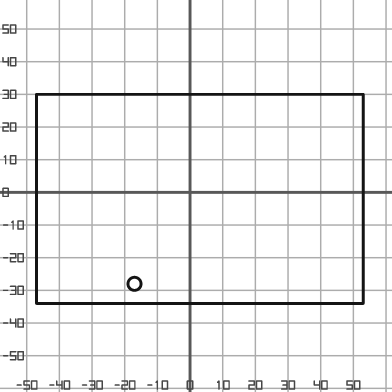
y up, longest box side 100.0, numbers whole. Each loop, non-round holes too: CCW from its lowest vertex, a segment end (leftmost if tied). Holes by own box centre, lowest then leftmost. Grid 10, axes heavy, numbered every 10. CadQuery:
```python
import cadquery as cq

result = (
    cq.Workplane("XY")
    .moveTo(-47.0, -34.0)
    .lineTo(53.0, -34.0)
    .lineTo(53.0, 30.0)
    .lineTo(-47.0, 30.0)
    .close()
    .moveTo(-17.0, -28.0)
    .circle(2.0)
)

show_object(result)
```